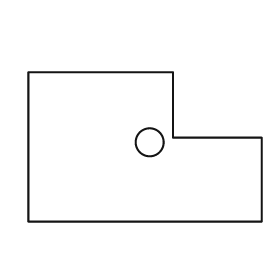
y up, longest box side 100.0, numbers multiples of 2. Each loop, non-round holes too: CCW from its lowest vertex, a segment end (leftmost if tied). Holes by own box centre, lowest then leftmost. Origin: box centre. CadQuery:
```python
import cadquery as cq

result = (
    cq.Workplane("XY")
    .moveTo(-50.0, -32.0)
    .lineTo(50.0, -32.0)
    .lineTo(50.0, 4.0)
    .lineTo(12.0, 4.0)
    .lineTo(12.0, 32.0)
    .lineTo(-50.0, 32.0)
    .close()
    .moveTo(2.0, 2.0)
    .circle(6.0)
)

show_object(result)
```